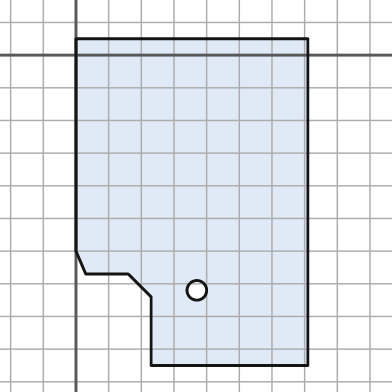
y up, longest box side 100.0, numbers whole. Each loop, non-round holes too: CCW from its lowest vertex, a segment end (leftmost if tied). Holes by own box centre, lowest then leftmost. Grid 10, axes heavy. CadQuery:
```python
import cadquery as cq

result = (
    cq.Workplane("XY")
    .moveTo(23.0, -95.0)
    .lineTo(71.0, -95.0)
    .lineTo(71.0, 5.0)
    .lineTo(0.0, 5.0)
    .lineTo(0.0, -60.0)
    .lineTo(3.0, -67.0)
    .lineTo(16.0, -67.0)
    .lineTo(23.0, -74.0)
    .close()
    .moveTo(37.0, -72.0)
    .circle(3.0)
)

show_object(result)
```